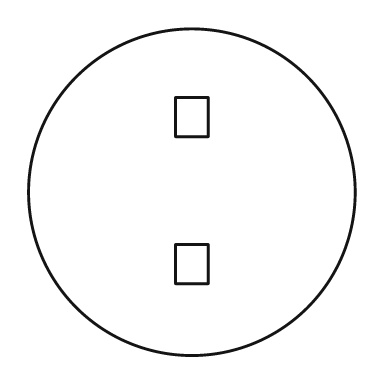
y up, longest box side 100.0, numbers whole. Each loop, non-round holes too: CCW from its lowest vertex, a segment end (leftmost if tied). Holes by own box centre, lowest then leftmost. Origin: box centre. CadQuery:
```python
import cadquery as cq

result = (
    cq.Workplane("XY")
    .moveTo(0.0, 0.0)
    .circle(50.0)
    .moveTo(-5.0, -28.0)
    .lineTo(5.0, -28.0)
    .lineTo(5.0, -16.0)
    .lineTo(-5.0, -16.0)
    .close()
    .moveTo(-5.0, 17.0)
    .lineTo(5.0, 17.0)
    .lineTo(5.0, 29.0)
    .lineTo(-5.0, 29.0)
    .close()
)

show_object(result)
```